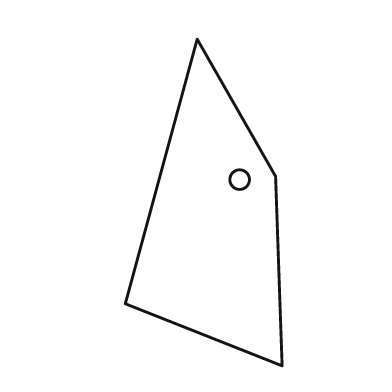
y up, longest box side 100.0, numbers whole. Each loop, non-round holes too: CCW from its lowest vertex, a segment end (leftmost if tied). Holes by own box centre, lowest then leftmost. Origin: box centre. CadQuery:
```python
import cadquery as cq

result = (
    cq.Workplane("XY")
    .moveTo(24.0, -50.0)
    .lineTo(22.0, 8.0)
    .lineTo(-2.0, 50.0)
    .lineTo(-24.0, -31.0)
    .close()
    .moveTo(11.0, 7.0)
    .circle(3.0)
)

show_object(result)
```